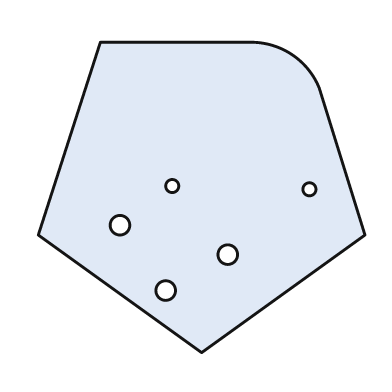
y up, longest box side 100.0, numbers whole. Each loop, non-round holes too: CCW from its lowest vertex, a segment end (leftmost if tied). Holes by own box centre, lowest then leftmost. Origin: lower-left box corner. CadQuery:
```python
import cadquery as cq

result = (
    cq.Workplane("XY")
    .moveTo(50.0, 0.0)
    .lineTo(100.0, 36.0)
    .lineTo(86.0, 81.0)
    .threePointArc((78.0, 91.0), (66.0, 95.0))
    .lineTo(19.0, 95.0)
    .lineTo(0.0, 36.0)
    .close()
    .moveTo(39.0, 19.0)
    .circle(3.0)
    .moveTo(58.0, 30.0)
    .circle(3.0)
    .moveTo(25.0, 39.0)
    .circle(3.0)
    .moveTo(83.0, 50.0)
    .circle(2.0)
    .moveTo(41.0, 51.0)
    .circle(2.0)
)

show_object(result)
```